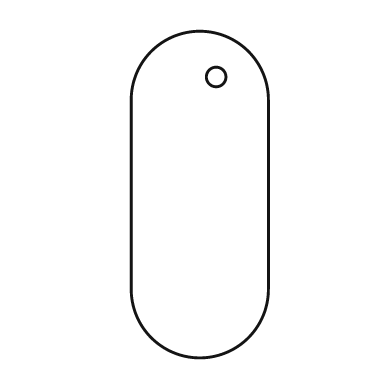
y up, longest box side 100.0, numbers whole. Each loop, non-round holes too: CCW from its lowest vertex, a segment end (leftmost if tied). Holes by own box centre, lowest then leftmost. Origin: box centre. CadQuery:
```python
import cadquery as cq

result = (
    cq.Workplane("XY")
    .moveTo(-21.0, -29.0)
    .threePointArc((0.0, -50.0), (21.0, -29.0))
    .lineTo(21.0, 29.0)
    .threePointArc((0.0, 50.0), (-21.0, 29.0))
    .close()
    .moveTo(5.0, 36.0)
    .circle(3.0)
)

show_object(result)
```